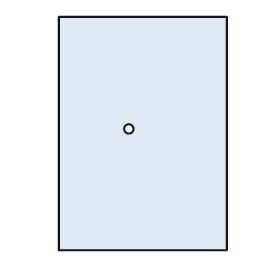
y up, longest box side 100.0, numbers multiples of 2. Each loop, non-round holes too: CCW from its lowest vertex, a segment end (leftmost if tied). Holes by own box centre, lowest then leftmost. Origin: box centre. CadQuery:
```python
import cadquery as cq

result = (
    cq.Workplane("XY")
    .moveTo(-36.0, -50.0)
    .lineTo(36.0, -50.0)
    .lineTo(36.0, 50.0)
    .lineTo(-36.0, 50.0)
    .close()
    .moveTo(-6.0, 2.0)
    .circle(2.0)
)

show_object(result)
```